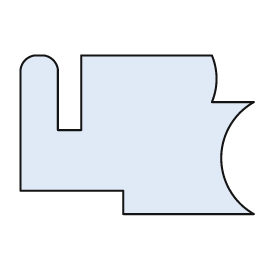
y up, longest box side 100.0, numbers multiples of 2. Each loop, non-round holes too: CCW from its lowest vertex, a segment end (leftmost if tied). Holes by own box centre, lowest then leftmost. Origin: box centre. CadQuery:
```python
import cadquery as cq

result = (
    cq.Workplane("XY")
    .moveTo(-6.0, -34.0)
    .lineTo(50.0, -34.0)
    .threePointArc((36.0, -10.0), (50.0, 14.0))
    .lineTo(32.0, 14.0)
    .threePointArc((34.0, 24.0), (32.0, 34.0))
    .lineTo(-24.0, 34.0)
    .lineTo(-24.0, 2.0)
    .lineTo(-34.0, 2.0)
    .lineTo(-34.0, 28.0)
    .threePointArc((-36.0, 32.0), (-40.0, 34.0))
    .lineTo(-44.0, 34.0)
    .threePointArc((-48.0, 32.0), (-50.0, 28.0))
    .lineTo(-50.0, -24.0)
    .lineTo(-6.0, -24.0)
    .close()
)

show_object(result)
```